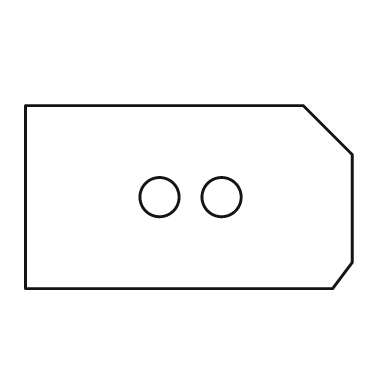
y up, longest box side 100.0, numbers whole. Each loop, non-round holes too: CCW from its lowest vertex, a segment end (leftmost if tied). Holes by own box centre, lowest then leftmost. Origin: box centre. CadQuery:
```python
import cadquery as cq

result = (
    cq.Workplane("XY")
    .moveTo(-50.0, -28.0)
    .lineTo(44.0, -28.0)
    .lineTo(50.0, -20.0)
    .lineTo(50.0, 13.0)
    .lineTo(35.0, 28.0)
    .lineTo(-50.0, 28.0)
    .close()
    .moveTo(-9.0, 0.0)
    .circle(6.0)
    .moveTo(10.0, 0.0)
    .circle(6.0)
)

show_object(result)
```